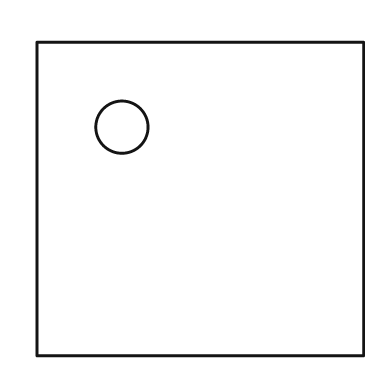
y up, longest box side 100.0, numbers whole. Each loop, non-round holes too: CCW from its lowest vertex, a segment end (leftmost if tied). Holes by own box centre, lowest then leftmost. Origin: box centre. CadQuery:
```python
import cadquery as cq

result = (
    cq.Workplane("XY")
    .moveTo(-50.0, -48.0)
    .lineTo(50.0, -48.0)
    .lineTo(50.0, 48.0)
    .lineTo(-50.0, 48.0)
    .close()
    .moveTo(-24.0, 22.0)
    .circle(8.0)
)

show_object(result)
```